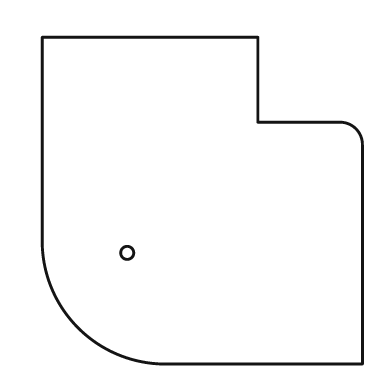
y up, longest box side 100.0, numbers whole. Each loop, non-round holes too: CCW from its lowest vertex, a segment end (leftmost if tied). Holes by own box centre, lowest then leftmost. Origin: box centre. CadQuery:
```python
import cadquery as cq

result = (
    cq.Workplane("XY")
    .moveTo(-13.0, -50.0)
    .lineTo(49.0, -50.0)
    .lineTo(49.0, 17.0)
    .threePointArc((47.0, 22.0), (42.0, 24.0))
    .lineTo(17.0, 24.0)
    .lineTo(17.0, 50.0)
    .lineTo(-49.0, 50.0)
    .lineTo(-49.0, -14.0)
    .threePointArc((-38.0, -39.0), (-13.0, -50.0))
    .close()
    .moveTo(-23.0, -16.0)
    .circle(2.0)
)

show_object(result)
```